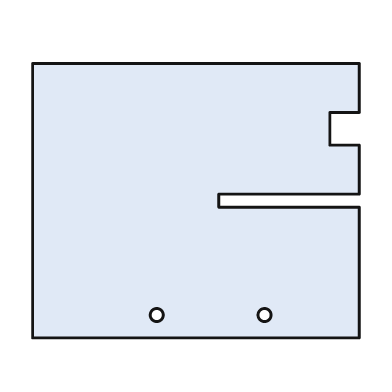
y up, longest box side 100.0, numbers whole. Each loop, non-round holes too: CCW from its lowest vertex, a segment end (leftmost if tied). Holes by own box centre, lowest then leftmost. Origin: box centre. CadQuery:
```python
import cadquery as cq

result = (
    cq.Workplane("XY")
    .moveTo(-50.0, -42.0)
    .lineTo(50.0, -42.0)
    .lineTo(50.0, -2.0)
    .lineTo(7.0, -2.0)
    .lineTo(7.0, 2.0)
    .lineTo(50.0, 2.0)
    .lineTo(50.0, 17.0)
    .lineTo(41.0, 17.0)
    .lineTo(41.0, 27.0)
    .lineTo(50.0, 27.0)
    .lineTo(50.0, 42.0)
    .lineTo(-50.0, 42.0)
    .close()
    .moveTo(-12.0, -35.0)
    .circle(2.0)
    .moveTo(21.0, -35.0)
    .circle(2.0)
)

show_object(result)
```